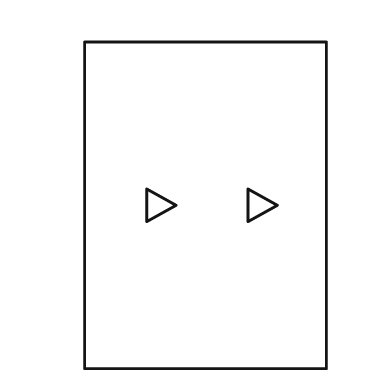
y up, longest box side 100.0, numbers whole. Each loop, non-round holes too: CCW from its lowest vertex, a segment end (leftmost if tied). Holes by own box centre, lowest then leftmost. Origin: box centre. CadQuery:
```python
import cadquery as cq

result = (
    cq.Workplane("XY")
    .moveTo(-37.0, -50.0)
    .lineTo(37.0, -50.0)
    .lineTo(37.0, 50.0)
    .lineTo(-37.0, 50.0)
    .close()
    .moveTo(-18.0, -5.0)
    .lineTo(-9.0, 0.0)
    .lineTo(-18.0, 5.0)
    .close()
    .moveTo(13.0, -5.0)
    .lineTo(22.0, 0.0)
    .lineTo(13.0, 5.0)
    .close()
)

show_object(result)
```